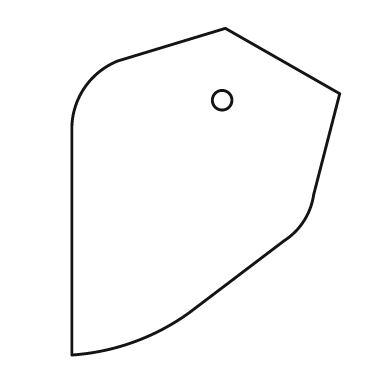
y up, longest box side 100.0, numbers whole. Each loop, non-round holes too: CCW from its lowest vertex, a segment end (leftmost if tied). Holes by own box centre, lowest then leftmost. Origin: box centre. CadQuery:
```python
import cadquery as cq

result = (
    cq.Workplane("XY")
    .moveTo(-41.0, -50.0)
    .threePointArc((-22.0, -46.0), (-5.0, -37.0))
    .lineTo(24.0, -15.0)
    .threePointArc((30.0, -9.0), (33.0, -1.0))
    .lineTo(41.0, 30.0)
    .lineTo(6.0, 50.0)
    .lineTo(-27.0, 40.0)
    .threePointArc((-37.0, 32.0), (-41.0, 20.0))
    .close()
    .moveTo(5.0, 28.0)
    .circle(3.0)
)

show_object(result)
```